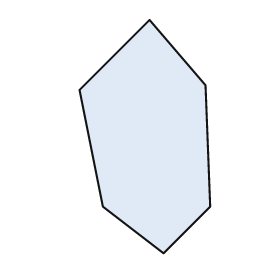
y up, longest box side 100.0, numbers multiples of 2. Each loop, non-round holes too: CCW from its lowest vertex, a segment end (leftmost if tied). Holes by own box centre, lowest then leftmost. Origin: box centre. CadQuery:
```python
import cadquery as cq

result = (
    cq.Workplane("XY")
    .moveTo(8.0, -50.0)
    .lineTo(28.0, -30.0)
    .lineTo(26.0, 22.0)
    .lineTo(2.0, 50.0)
    .lineTo(-28.0, 20.0)
    .lineTo(-18.0, -30.0)
    .close()
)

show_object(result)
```